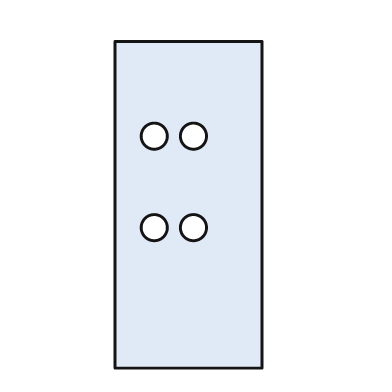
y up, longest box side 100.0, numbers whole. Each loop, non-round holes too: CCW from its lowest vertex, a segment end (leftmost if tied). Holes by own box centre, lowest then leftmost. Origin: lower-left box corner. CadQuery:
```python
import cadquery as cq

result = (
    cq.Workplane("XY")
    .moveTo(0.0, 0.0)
    .lineTo(45.0, 0.0)
    .lineTo(45.0, 100.0)
    .lineTo(0.0, 100.0)
    .close()
    .moveTo(12.0, 43.0)
    .circle(4.0)
    .moveTo(24.0, 43.0)
    .circle(4.0)
    .moveTo(12.0, 71.0)
    .circle(4.0)
    .moveTo(24.0, 71.0)
    .circle(4.0)
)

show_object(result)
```